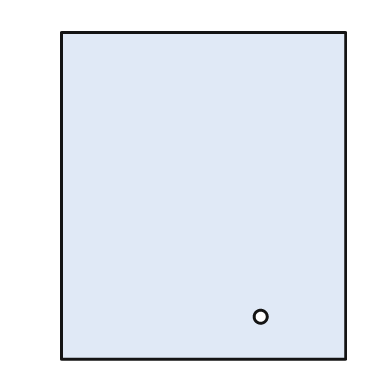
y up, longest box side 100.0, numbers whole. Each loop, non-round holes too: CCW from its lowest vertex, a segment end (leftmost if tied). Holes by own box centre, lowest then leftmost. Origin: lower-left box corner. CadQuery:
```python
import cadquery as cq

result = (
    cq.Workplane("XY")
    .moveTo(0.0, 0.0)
    .lineTo(87.0, 0.0)
    .lineTo(87.0, 100.0)
    .lineTo(0.0, 100.0)
    .close()
    .moveTo(61.0, 13.0)
    .circle(2.0)
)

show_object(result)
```